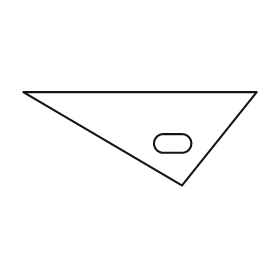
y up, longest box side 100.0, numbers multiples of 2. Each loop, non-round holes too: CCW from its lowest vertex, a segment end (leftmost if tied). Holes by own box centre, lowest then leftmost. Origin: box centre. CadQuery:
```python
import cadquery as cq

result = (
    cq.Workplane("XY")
    .moveTo(18.0, -20.0)
    .lineTo(50.0, 20.0)
    .lineTo(-50.0, 20.0)
    .close()
    .moveTo(10.0, -6.0)
    .lineTo(18.0, -6.0)
    .threePointArc((22.0, -2.0), (18.0, 2.0))
    .lineTo(10.0, 2.0)
    .threePointArc((6.0, -2.0), (10.0, -6.0))
    .close()
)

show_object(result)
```